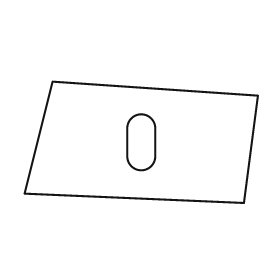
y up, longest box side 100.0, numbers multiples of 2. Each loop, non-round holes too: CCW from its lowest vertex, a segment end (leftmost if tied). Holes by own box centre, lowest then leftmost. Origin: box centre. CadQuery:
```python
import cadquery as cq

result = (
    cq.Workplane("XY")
    .moveTo(44.0, -26.0)
    .lineTo(50.0, 20.0)
    .lineTo(-38.0, 26.0)
    .lineTo(-50.0, -22.0)
    .close()
    .moveTo(-6.0, -6.0)
    .threePointArc((0.0, -12.0), (6.0, -6.0))
    .lineTo(6.0, 6.0)
    .threePointArc((0.0, 12.0), (-6.0, 6.0))
    .close()
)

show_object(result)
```